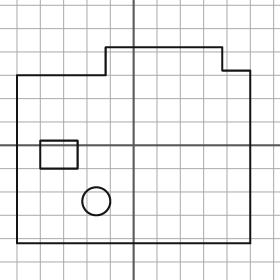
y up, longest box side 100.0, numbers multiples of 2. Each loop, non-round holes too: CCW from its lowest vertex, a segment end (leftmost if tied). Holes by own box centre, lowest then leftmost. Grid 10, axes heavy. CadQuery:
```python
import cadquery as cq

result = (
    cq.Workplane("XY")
    .moveTo(-50.0, -42.0)
    .lineTo(50.0, -42.0)
    .lineTo(50.0, 32.0)
    .lineTo(38.0, 32.0)
    .lineTo(38.0, 42.0)
    .lineTo(-12.0, 42.0)
    .lineTo(-12.0, 30.0)
    .lineTo(-50.0, 30.0)
    .close()
    .moveTo(-16.0, -24.0)
    .circle(6.0)
    .moveTo(-40.0, -10.0)
    .lineTo(-24.0, -10.0)
    .lineTo(-24.0, 2.0)
    .lineTo(-40.0, 2.0)
    .close()
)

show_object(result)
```